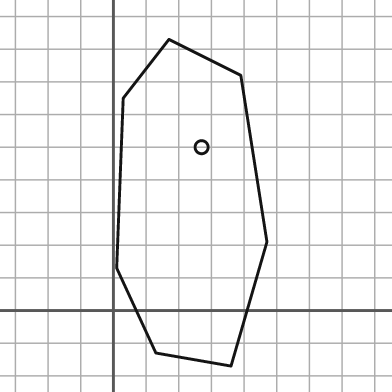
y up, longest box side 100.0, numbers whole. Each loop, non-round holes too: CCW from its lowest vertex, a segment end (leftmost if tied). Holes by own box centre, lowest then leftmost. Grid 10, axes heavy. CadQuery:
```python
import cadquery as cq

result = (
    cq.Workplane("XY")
    .moveTo(36.0, -17.0)
    .lineTo(47.0, 21.0)
    .lineTo(39.0, 72.0)
    .lineTo(17.0, 83.0)
    .lineTo(3.0, 65.0)
    .lineTo(1.0, 13.0)
    .lineTo(13.0, -13.0)
    .close()
    .moveTo(27.0, 50.0)
    .circle(2.0)
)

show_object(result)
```